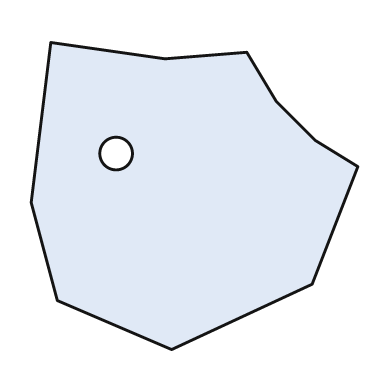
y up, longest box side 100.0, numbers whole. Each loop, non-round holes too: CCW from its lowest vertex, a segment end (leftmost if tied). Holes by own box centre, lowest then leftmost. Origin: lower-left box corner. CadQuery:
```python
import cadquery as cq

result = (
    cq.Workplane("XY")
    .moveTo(43.0, 0.0)
    .lineTo(86.0, 20.0)
    .lineTo(100.0, 56.0)
    .lineTo(87.0, 64.0)
    .lineTo(75.0, 76.0)
    .lineTo(66.0, 91.0)
    .lineTo(41.0, 89.0)
    .lineTo(6.0, 94.0)
    .lineTo(0.0, 45.0)
    .lineTo(8.0, 15.0)
    .close()
    .moveTo(26.0, 60.0)
    .circle(5.0)
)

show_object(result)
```